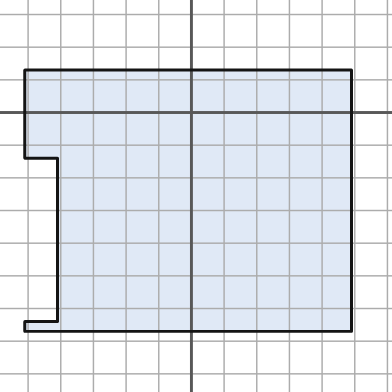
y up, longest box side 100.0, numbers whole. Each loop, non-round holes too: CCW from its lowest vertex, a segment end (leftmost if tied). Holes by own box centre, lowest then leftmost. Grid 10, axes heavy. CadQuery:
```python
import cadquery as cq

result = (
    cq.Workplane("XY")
    .moveTo(-51.0, -67.0)
    .lineTo(49.0, -67.0)
    .lineTo(49.0, 13.0)
    .lineTo(-51.0, 13.0)
    .lineTo(-51.0, -14.0)
    .lineTo(-41.0, -14.0)
    .lineTo(-41.0, -64.0)
    .lineTo(-51.0, -64.0)
    .close()
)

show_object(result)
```